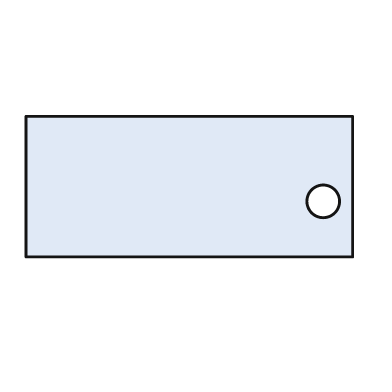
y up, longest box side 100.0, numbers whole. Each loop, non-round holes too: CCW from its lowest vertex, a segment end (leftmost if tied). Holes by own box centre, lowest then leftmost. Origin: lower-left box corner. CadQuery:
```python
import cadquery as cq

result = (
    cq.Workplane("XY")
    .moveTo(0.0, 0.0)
    .lineTo(100.0, 0.0)
    .lineTo(100.0, 43.0)
    .lineTo(0.0, 43.0)
    .close()
    .moveTo(91.0, 17.0)
    .circle(5.0)
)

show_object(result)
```